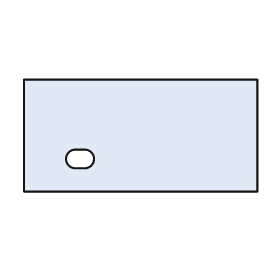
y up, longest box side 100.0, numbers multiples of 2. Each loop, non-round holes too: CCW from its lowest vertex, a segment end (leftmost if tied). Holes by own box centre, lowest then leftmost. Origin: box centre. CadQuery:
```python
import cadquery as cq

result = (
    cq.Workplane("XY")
    .moveTo(-50.0, -24.0)
    .lineTo(50.0, -24.0)
    .lineTo(50.0, 24.0)
    .lineTo(-50.0, 24.0)
    .close()
    .moveTo(-28.0, -14.0)
    .lineTo(-24.0, -14.0)
    .threePointArc((-20.0, -10.0), (-24.0, -6.0))
    .lineTo(-28.0, -6.0)
    .threePointArc((-32.0, -10.0), (-28.0, -14.0))
    .close()
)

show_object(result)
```